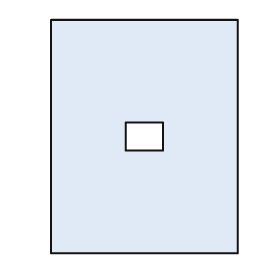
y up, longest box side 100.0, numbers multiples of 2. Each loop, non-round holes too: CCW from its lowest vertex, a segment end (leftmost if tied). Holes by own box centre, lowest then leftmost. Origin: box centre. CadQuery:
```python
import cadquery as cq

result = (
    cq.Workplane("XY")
    .moveTo(-40.0, -50.0)
    .lineTo(40.0, -50.0)
    .lineTo(40.0, 50.0)
    .lineTo(-40.0, 50.0)
    .close()
    .moveTo(-8.0, -6.0)
    .lineTo(8.0, -6.0)
    .lineTo(8.0, 6.0)
    .lineTo(-8.0, 6.0)
    .close()
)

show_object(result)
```